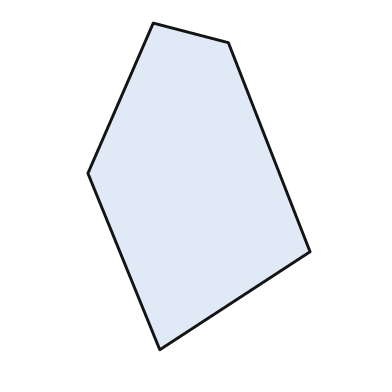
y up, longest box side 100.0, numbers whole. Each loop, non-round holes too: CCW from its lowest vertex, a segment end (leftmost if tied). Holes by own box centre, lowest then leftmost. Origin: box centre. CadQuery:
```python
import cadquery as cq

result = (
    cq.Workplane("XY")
    .moveTo(-12.0, -50.0)
    .lineTo(34.0, -20.0)
    .lineTo(9.0, 44.0)
    .lineTo(-14.0, 50.0)
    .lineTo(-34.0, 4.0)
    .close()
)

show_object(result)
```